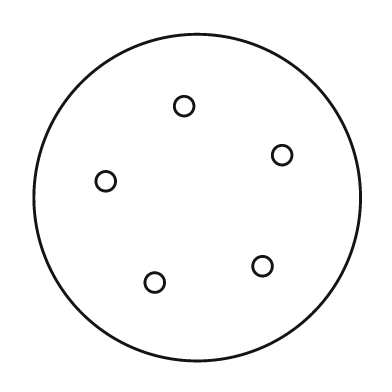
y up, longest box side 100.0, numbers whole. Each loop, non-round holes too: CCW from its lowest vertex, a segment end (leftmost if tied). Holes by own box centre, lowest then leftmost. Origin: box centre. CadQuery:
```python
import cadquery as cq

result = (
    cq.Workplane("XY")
    .moveTo(0.0, 0.0)
    .circle(50.0)
    .moveTo(-13.0, -26.0)
    .circle(3.0)
    .moveTo(20.0, -21.0)
    .circle(3.0)
    .moveTo(-28.0, 5.0)
    .circle(3.0)
    .moveTo(26.0, 13.0)
    .circle(3.0)
    .moveTo(-4.0, 28.0)
    .circle(3.0)
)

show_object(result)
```